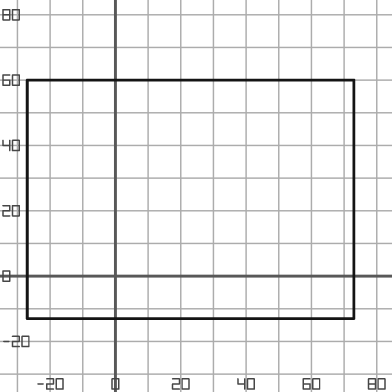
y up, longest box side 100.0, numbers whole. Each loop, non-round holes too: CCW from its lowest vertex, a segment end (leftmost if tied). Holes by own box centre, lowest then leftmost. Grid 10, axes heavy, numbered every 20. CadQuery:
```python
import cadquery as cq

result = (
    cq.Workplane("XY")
    .moveTo(-27.0, -13.0)
    .lineTo(73.0, -13.0)
    .lineTo(73.0, 60.0)
    .lineTo(-27.0, 60.0)
    .close()
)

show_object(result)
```